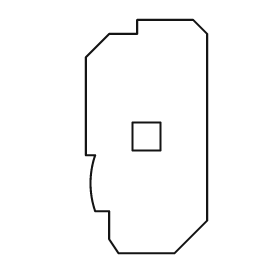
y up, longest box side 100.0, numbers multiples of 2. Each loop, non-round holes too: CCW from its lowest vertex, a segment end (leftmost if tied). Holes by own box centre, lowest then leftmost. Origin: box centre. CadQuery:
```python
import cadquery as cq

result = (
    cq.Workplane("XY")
    .moveTo(-12.0, -50.0)
    .lineTo(12.0, -50.0)
    .lineTo(26.0, -36.0)
    .lineTo(26.0, 44.0)
    .lineTo(20.0, 50.0)
    .lineTo(-4.0, 50.0)
    .lineTo(-4.0, 44.0)
    .lineTo(-16.0, 44.0)
    .lineTo(-26.0, 34.0)
    .lineTo(-26.0, -8.0)
    .lineTo(-22.0, -8.0)
    .threePointArc((-24.0, -20.0), (-22.0, -32.0))
    .lineTo(-16.0, -32.0)
    .lineTo(-16.0, -44.0)
    .close()
    .moveTo(-6.0, -6.0)
    .lineTo(6.0, -6.0)
    .lineTo(6.0, 6.0)
    .lineTo(-6.0, 6.0)
    .close()
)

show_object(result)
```